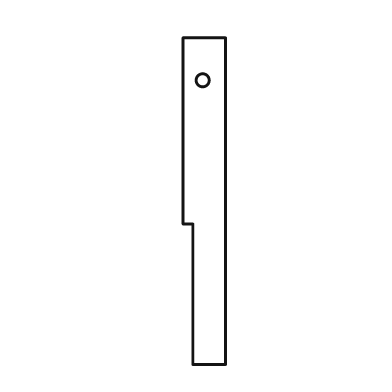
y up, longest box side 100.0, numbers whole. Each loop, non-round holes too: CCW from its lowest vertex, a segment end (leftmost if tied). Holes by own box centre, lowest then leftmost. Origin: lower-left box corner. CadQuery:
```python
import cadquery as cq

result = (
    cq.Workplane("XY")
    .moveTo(3.0, 0.0)
    .lineTo(13.0, 0.0)
    .lineTo(13.0, 100.0)
    .lineTo(0.0, 100.0)
    .lineTo(0.0, 43.0)
    .lineTo(3.0, 43.0)
    .close()
    .moveTo(6.0, 87.0)
    .circle(2.0)
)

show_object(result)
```